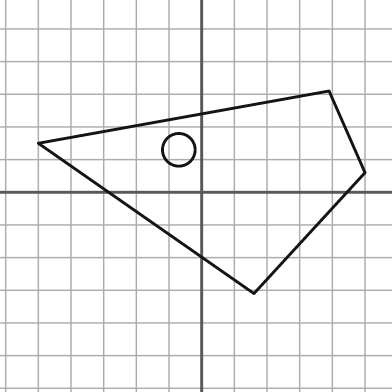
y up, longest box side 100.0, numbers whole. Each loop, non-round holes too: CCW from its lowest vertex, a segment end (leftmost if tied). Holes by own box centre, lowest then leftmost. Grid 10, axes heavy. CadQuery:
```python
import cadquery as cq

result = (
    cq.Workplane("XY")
    .moveTo(16.0, -31.0)
    .lineTo(50.0, 6.0)
    .lineTo(39.0, 31.0)
    .lineTo(-50.0, 15.0)
    .close()
    .moveTo(-7.0, 13.0)
    .circle(5.0)
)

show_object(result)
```